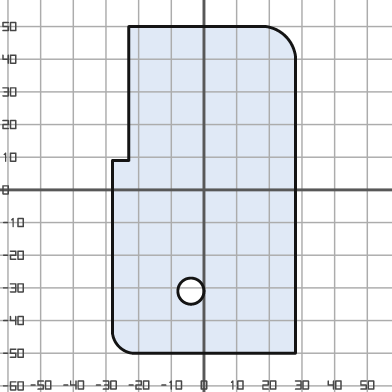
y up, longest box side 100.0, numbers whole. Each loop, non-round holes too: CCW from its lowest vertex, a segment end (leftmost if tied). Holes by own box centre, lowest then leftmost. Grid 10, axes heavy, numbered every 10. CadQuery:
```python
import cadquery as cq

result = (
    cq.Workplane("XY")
    .moveTo(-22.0, -50.0)
    .lineTo(28.0, -50.0)
    .lineTo(28.0, 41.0)
    .threePointArc((25.0, 47.0), (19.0, 50.0))
    .lineTo(-23.0, 50.0)
    .lineTo(-23.0, 9.0)
    .lineTo(-28.0, 9.0)
    .lineTo(-28.0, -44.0)
    .threePointArc((-26.0, -48.0), (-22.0, -50.0))
    .close()
    .moveTo(-4.0, -31.0)
    .circle(4.0)
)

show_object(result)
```